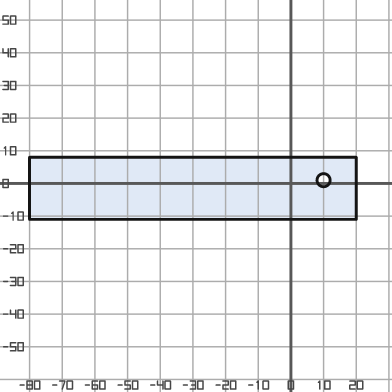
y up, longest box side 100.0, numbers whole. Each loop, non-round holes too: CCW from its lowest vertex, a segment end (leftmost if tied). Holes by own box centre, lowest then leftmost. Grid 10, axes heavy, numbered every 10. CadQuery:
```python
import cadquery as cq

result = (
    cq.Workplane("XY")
    .moveTo(-80.0, -11.0)
    .lineTo(20.0, -11.0)
    .lineTo(20.0, 8.0)
    .lineTo(-80.0, 8.0)
    .close()
    .moveTo(10.0, 1.0)
    .circle(2.0)
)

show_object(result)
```